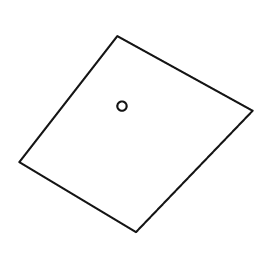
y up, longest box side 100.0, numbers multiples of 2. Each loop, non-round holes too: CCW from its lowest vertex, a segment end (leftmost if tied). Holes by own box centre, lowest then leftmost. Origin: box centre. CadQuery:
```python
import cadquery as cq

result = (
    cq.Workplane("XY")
    .moveTo(0.0, -42.0)
    .lineTo(50.0, 10.0)
    .lineTo(-8.0, 42.0)
    .lineTo(-50.0, -12.0)
    .close()
    .moveTo(-6.0, 12.0)
    .circle(2.0)
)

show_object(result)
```